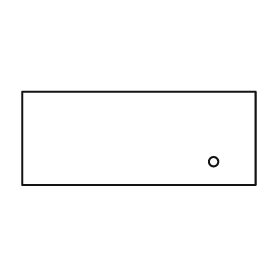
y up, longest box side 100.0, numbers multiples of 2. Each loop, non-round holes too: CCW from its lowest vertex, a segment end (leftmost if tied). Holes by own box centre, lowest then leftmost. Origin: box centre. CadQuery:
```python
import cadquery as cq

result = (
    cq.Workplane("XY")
    .moveTo(-50.0, -20.0)
    .lineTo(50.0, -20.0)
    .lineTo(50.0, 20.0)
    .lineTo(-50.0, 20.0)
    .close()
    .moveTo(32.0, -10.0)
    .circle(2.0)
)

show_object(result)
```